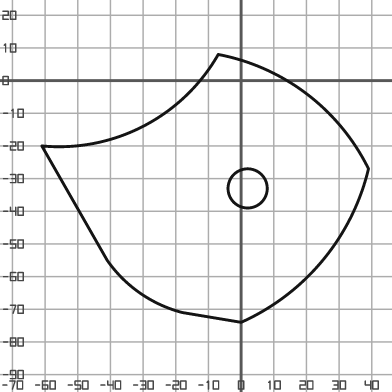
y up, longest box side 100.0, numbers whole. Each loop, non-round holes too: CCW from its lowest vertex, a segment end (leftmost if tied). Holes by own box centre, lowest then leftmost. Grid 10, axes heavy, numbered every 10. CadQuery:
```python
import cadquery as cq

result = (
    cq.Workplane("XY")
    .moveTo(0.0, -74.0)
    .threePointArc((25.0, -55.0), (39.0, -27.0))
    .threePointArc((20.0, -4.0), (-7.0, 8.0))
    .threePointArc((-30.0, -14.0), (-61.0, -20.0))
    .lineTo(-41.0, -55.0)
    .threePointArc((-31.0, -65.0), (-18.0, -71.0))
    .close()
    .moveTo(2.0, -33.0)
    .circle(6.0)
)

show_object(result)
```